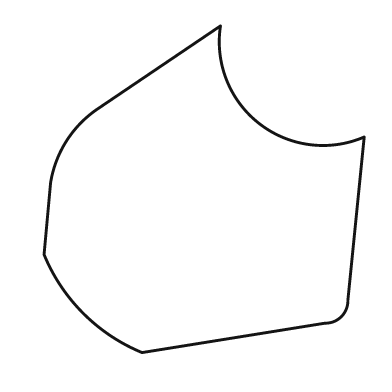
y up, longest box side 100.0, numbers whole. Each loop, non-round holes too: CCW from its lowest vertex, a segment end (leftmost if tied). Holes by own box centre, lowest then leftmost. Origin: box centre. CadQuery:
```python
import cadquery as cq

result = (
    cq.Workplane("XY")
    .moveTo(-19.0, -50.0)
    .lineTo(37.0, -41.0)
    .threePointArc((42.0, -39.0), (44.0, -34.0))
    .lineTo(49.0, 16.0)
    .threePointArc((17.0, 20.0), (5.0, 50.0))
    .lineTo(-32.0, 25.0)
    .threePointArc((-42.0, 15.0), (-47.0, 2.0))
    .lineTo(-49.0, -20.0)
    .threePointArc((-37.0, -38.0), (-19.0, -50.0))
    .close()
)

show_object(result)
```